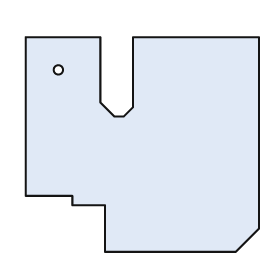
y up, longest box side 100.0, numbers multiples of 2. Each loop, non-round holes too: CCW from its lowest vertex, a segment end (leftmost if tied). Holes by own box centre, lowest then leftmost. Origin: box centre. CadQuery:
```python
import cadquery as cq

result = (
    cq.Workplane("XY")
    .moveTo(-16.0, -46.0)
    .lineTo(40.0, -46.0)
    .lineTo(50.0, -36.0)
    .lineTo(50.0, 46.0)
    .lineTo(-4.0, 46.0)
    .lineTo(-4.0, 16.0)
    .lineTo(-8.0, 12.0)
    .lineTo(-12.0, 12.0)
    .lineTo(-18.0, 18.0)
    .lineTo(-18.0, 46.0)
    .lineTo(-50.0, 46.0)
    .lineTo(-50.0, -22.0)
    .lineTo(-30.0, -22.0)
    .lineTo(-30.0, -26.0)
    .lineTo(-16.0, -26.0)
    .close()
    .moveTo(-36.0, 32.0)
    .circle(2.0)
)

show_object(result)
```